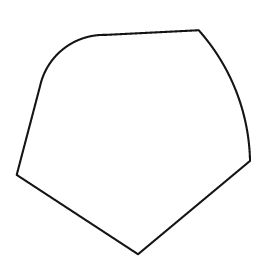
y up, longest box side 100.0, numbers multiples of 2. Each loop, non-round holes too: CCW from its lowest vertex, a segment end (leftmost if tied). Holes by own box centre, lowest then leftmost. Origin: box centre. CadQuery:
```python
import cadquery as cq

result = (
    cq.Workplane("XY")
    .moveTo(2.0, -48.0)
    .lineTo(50.0, -8.0)
    .threePointArc((44.0, 22.0), (28.0, 48.0))
    .lineTo(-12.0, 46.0)
    .threePointArc((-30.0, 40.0), (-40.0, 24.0))
    .lineTo(-50.0, -14.0)
    .close()
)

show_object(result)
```